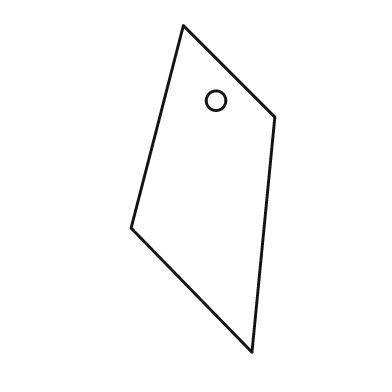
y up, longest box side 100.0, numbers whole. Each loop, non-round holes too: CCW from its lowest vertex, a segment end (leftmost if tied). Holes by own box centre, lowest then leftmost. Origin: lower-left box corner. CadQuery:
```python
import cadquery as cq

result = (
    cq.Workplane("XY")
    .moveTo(37.0, 0.0)
    .lineTo(44.0, 72.0)
    .lineTo(16.0, 100.0)
    .lineTo(0.0, 38.0)
    .close()
    .moveTo(26.0, 77.0)
    .circle(3.0)
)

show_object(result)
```